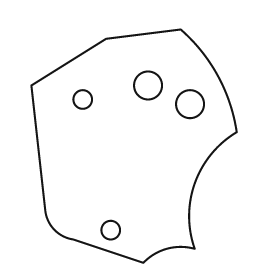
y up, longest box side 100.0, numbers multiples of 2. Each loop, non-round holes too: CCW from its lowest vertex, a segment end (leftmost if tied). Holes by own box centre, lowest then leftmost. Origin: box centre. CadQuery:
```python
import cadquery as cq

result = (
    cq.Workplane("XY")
    .moveTo(4.0, -50.0)
    .threePointArc((14.0, -44.0), (26.0, -44.0))
    .threePointArc((26.0, -16.0), (44.0, 6.0))
    .threePointArc((36.0, 30.0), (20.0, 50.0))
    .lineTo(-12.0, 46.0)
    .lineTo(-44.0, 26.0)
    .lineTo(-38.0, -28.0)
    .threePointArc((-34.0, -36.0), (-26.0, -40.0))
    .close()
    .moveTo(-10.0, -36.0)
    .circle(4.0)
    .moveTo(24.0, 18.0)
    .circle(6.0)
    .moveTo(-22.0, 20.0)
    .circle(4.0)
    .moveTo(6.0, 26.0)
    .circle(6.0)
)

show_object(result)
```